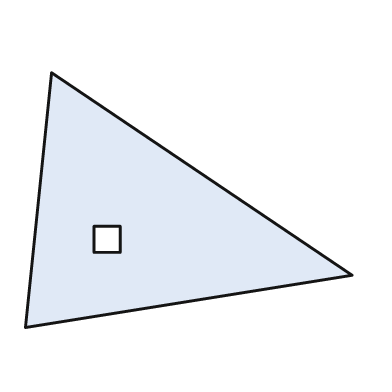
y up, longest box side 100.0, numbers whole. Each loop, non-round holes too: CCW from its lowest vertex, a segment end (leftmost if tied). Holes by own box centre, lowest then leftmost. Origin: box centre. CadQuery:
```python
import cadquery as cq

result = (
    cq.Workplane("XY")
    .moveTo(-50.0, -39.0)
    .lineTo(50.0, -23.0)
    .lineTo(-42.0, 39.0)
    .close()
    .moveTo(-29.0, -16.0)
    .lineTo(-21.0, -16.0)
    .lineTo(-21.0, -8.0)
    .lineTo(-29.0, -8.0)
    .close()
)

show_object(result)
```